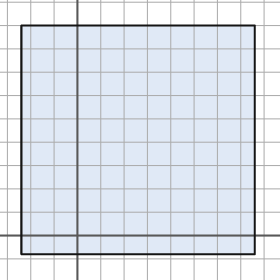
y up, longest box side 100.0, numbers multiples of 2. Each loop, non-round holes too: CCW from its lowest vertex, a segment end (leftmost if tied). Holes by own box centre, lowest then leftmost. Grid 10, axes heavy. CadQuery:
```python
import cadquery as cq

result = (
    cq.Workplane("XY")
    .moveTo(-24.0, -8.0)
    .lineTo(76.0, -8.0)
    .lineTo(76.0, 90.0)
    .lineTo(-24.0, 90.0)
    .close()
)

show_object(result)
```